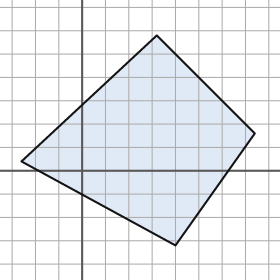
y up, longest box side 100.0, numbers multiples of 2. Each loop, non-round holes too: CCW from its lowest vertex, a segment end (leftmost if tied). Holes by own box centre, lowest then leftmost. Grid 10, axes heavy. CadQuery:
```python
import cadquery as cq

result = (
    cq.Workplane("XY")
    .moveTo(40.0, -32.0)
    .lineTo(74.0, 16.0)
    .lineTo(32.0, 58.0)
    .lineTo(-26.0, 4.0)
    .close()
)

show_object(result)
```